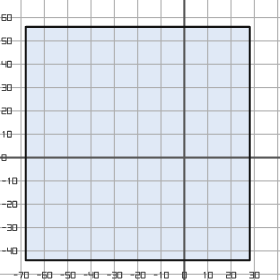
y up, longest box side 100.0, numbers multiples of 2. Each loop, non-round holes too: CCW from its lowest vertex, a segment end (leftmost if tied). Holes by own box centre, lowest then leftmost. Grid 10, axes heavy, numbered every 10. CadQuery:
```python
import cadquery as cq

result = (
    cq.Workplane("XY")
    .moveTo(-68.0, -44.0)
    .lineTo(28.0, -44.0)
    .lineTo(28.0, 56.0)
    .lineTo(-68.0, 56.0)
    .close()
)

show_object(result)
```